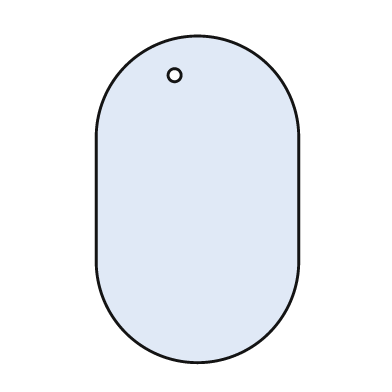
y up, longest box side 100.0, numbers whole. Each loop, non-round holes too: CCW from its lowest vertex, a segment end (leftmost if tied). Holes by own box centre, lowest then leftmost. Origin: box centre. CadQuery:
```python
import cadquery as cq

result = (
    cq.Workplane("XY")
    .moveTo(-31.0, -19.0)
    .threePointArc((0.0, -50.0), (31.0, -19.0))
    .lineTo(31.0, 19.0)
    .threePointArc((0.0, 50.0), (-31.0, 19.0))
    .close()
    .moveTo(-7.0, 38.0)
    .circle(2.0)
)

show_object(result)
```